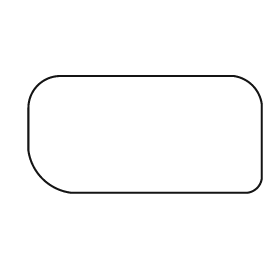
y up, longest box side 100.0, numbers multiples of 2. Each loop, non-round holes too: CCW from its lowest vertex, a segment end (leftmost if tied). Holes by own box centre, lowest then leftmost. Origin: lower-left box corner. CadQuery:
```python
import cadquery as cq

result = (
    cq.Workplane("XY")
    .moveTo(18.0, 0.0)
    .lineTo(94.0, 0.0)
    .threePointArc((98.0, 2.0), (100.0, 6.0))
    .lineTo(100.0, 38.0)
    .threePointArc((96.0, 46.0), (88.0, 50.0))
    .lineTo(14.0, 50.0)
    .threePointArc((4.0, 46.0), (0.0, 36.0))
    .lineTo(0.0, 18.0)
    .threePointArc((6.0, 6.0), (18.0, 0.0))
    .close()
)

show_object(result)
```